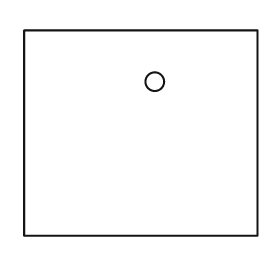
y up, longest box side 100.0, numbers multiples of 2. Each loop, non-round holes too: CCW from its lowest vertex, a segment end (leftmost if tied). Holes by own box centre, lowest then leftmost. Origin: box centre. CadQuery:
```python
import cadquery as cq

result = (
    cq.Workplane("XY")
    .moveTo(-50.0, -44.0)
    .lineTo(50.0, -44.0)
    .lineTo(50.0, 44.0)
    .lineTo(-50.0, 44.0)
    .close()
    .moveTo(6.0, 22.0)
    .circle(4.0)
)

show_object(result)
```